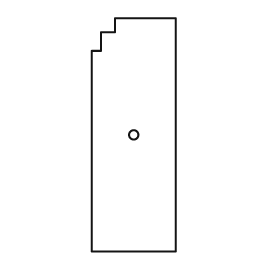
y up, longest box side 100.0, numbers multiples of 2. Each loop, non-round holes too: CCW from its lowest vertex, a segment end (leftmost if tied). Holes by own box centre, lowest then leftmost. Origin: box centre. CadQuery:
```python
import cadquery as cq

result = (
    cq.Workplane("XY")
    .moveTo(-18.0, -50.0)
    .lineTo(18.0, -50.0)
    .lineTo(18.0, 50.0)
    .lineTo(-8.0, 50.0)
    .lineTo(-8.0, 44.0)
    .lineTo(-14.0, 44.0)
    .lineTo(-14.0, 36.0)
    .lineTo(-18.0, 36.0)
    .close()
    .moveTo(0.0, 0.0)
    .circle(2.0)
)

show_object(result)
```